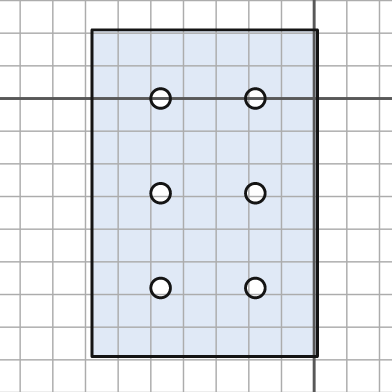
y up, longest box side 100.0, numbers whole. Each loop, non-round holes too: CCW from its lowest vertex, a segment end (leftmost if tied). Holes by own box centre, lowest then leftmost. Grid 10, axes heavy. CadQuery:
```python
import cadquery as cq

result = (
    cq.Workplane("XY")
    .moveTo(-68.0, -79.0)
    .lineTo(1.0, -79.0)
    .lineTo(1.0, 21.0)
    .lineTo(-68.0, 21.0)
    .close()
    .moveTo(-47.0, -58.0)
    .circle(3.0)
    .moveTo(-18.0, -58.0)
    .circle(3.0)
    .moveTo(-47.0, -29.0)
    .circle(3.0)
    .moveTo(-18.0, -29.0)
    .circle(3.0)
    .moveTo(-47.0, 0.0)
    .circle(3.0)
    .moveTo(-18.0, 0.0)
    .circle(3.0)
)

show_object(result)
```